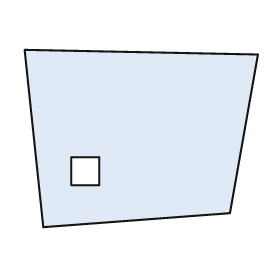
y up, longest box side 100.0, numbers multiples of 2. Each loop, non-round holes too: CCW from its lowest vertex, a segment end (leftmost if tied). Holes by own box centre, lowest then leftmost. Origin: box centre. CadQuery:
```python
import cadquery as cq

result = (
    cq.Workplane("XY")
    .moveTo(-42.0, -38.0)
    .lineTo(38.0, -32.0)
    .lineTo(50.0, 36.0)
    .lineTo(-50.0, 38.0)
    .close()
    .moveTo(-30.0, -20.0)
    .lineTo(-18.0, -20.0)
    .lineTo(-18.0, -8.0)
    .lineTo(-30.0, -8.0)
    .close()
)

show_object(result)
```